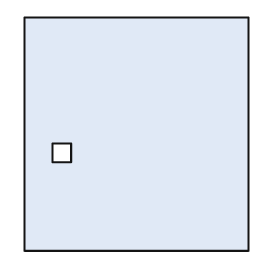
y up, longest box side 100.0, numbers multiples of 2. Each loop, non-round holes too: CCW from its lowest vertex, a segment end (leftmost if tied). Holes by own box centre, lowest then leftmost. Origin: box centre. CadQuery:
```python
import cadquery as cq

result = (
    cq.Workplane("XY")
    .moveTo(-48.0, -50.0)
    .lineTo(48.0, -50.0)
    .lineTo(48.0, 50.0)
    .lineTo(-48.0, 50.0)
    .close()
    .moveTo(-36.0, -12.0)
    .lineTo(-28.0, -12.0)
    .lineTo(-28.0, -4.0)
    .lineTo(-36.0, -4.0)
    .close()
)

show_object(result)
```